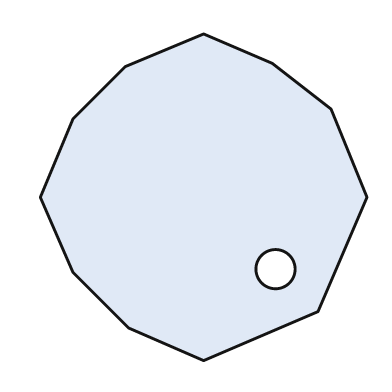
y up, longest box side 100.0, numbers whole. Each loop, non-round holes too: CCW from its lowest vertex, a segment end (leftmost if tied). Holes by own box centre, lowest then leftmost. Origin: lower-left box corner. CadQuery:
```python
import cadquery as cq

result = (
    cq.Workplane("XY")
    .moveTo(50.0, 0.0)
    .lineTo(85.0, 15.0)
    .lineTo(100.0, 50.0)
    .lineTo(89.0, 77.0)
    .lineTo(71.0, 91.0)
    .lineTo(50.0, 100.0)
    .lineTo(26.0, 90.0)
    .lineTo(10.0, 74.0)
    .lineTo(0.0, 50.0)
    .lineTo(10.0, 27.0)
    .lineTo(27.0, 10.0)
    .close()
    .moveTo(72.0, 28.0)
    .circle(6.0)
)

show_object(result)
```